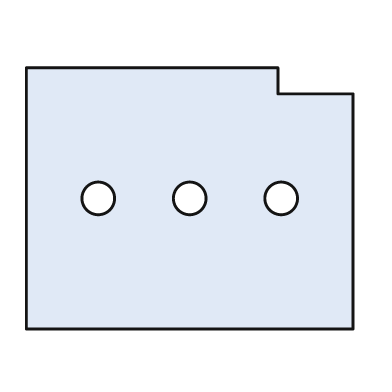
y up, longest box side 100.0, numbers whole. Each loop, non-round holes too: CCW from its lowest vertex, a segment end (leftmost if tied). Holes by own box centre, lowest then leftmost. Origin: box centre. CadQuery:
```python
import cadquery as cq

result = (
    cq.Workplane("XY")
    .moveTo(-50.0, -40.0)
    .lineTo(50.0, -40.0)
    .lineTo(50.0, 32.0)
    .lineTo(27.0, 32.0)
    .lineTo(27.0, 40.0)
    .lineTo(-50.0, 40.0)
    .close()
    .moveTo(-28.0, 0.0)
    .circle(5.0)
    .moveTo(0.0, 0.0)
    .circle(5.0)
    .moveTo(28.0, 0.0)
    .circle(5.0)
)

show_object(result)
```